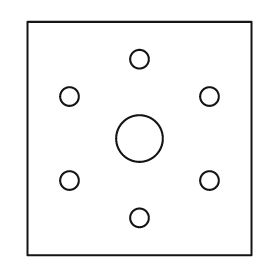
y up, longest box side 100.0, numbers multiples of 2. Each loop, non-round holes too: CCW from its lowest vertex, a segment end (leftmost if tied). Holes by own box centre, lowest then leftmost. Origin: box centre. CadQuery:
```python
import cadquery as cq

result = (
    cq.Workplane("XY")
    .moveTo(-48.0, -50.0)
    .lineTo(48.0, -50.0)
    .lineTo(48.0, 50.0)
    .lineTo(-48.0, 50.0)
    .close()
    .moveTo(0.0, -34.0)
    .circle(4.0)
    .moveTo(-30.0, -18.0)
    .circle(4.0)
    .moveTo(30.0, -18.0)
    .circle(4.0)
    .moveTo(0.0, 0.0)
    .circle(10.0)
    .moveTo(-30.0, 18.0)
    .circle(4.0)
    .moveTo(30.0, 18.0)
    .circle(4.0)
    .moveTo(0.0, 34.0)
    .circle(4.0)
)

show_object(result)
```